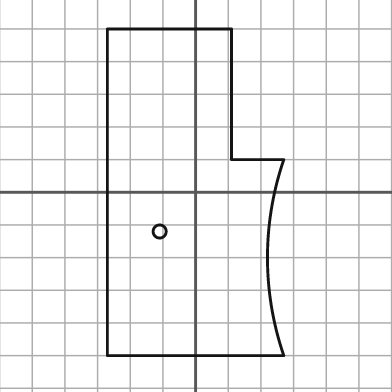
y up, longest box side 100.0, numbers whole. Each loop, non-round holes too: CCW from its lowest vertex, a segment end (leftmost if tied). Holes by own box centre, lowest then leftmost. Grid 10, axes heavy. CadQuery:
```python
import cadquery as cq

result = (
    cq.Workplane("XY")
    .moveTo(-27.0, -50.0)
    .lineTo(27.0, -50.0)
    .threePointArc((22.0, -20.0), (27.0, 10.0))
    .lineTo(11.0, 10.0)
    .lineTo(11.0, 50.0)
    .lineTo(-27.0, 50.0)
    .close()
    .moveTo(-11.0, -12.0)
    .circle(2.0)
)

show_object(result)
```